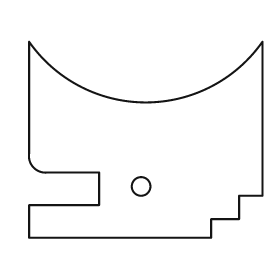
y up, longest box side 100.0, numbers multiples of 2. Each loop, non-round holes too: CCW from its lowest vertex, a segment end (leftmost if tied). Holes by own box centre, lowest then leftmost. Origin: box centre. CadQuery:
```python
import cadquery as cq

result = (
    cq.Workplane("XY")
    .moveTo(-50.0, -42.0)
    .lineTo(28.0, -42.0)
    .lineTo(28.0, -34.0)
    .lineTo(40.0, -34.0)
    .lineTo(40.0, -24.0)
    .lineTo(50.0, -24.0)
    .lineTo(50.0, 42.0)
    .threePointArc((0.0, 16.0), (-50.0, 42.0))
    .lineTo(-50.0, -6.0)
    .threePointArc((-48.0, -12.0), (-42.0, -14.0))
    .lineTo(-20.0, -14.0)
    .lineTo(-20.0, -28.0)
    .lineTo(-50.0, -28.0)
    .close()
    .moveTo(-2.0, -20.0)
    .circle(4.0)
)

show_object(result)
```